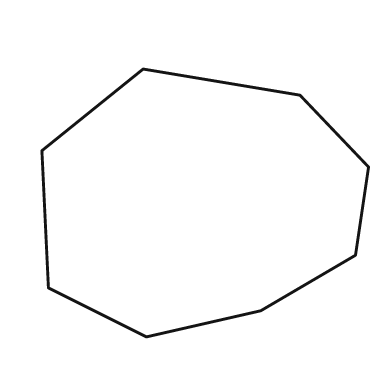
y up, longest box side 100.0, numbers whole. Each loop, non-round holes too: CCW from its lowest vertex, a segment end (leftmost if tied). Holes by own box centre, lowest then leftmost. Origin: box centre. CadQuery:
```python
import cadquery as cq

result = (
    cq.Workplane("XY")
    .moveTo(-18.0, -41.0)
    .lineTo(17.0, -33.0)
    .lineTo(46.0, -16.0)
    .lineTo(50.0, 11.0)
    .lineTo(29.0, 33.0)
    .lineTo(-19.0, 41.0)
    .lineTo(-50.0, 16.0)
    .lineTo(-48.0, -26.0)
    .close()
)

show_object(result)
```